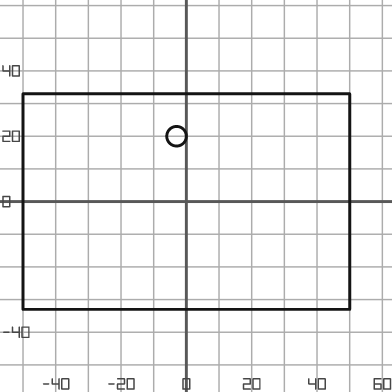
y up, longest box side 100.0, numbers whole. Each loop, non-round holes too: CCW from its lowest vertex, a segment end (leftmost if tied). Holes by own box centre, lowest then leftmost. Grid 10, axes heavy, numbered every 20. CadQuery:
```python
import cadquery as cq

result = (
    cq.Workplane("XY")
    .moveTo(-50.0, -33.0)
    .lineTo(50.0, -33.0)
    .lineTo(50.0, 33.0)
    .lineTo(-50.0, 33.0)
    .close()
    .moveTo(-3.0, 20.0)
    .circle(3.0)
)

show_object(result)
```